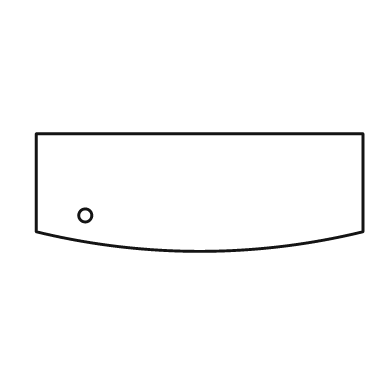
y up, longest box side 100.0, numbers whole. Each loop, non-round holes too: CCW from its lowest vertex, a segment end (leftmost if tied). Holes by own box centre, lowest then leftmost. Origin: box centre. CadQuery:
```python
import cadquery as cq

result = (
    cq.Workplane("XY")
    .moveTo(-50.0, -12.0)
    .threePointArc((0.0, -18.0), (50.0, -12.0))
    .lineTo(50.0, 18.0)
    .lineTo(-50.0, 18.0)
    .close()
    .moveTo(-35.0, -7.0)
    .circle(2.0)
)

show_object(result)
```